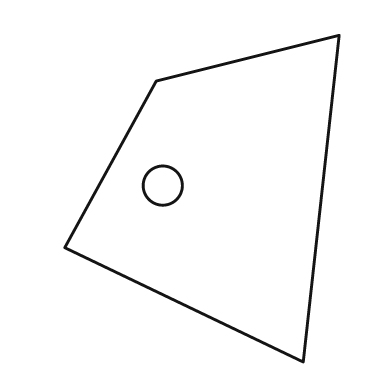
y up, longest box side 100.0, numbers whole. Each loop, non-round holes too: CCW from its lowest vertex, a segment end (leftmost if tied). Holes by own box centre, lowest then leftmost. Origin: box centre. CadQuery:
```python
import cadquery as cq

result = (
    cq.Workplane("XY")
    .moveTo(31.0, -50.0)
    .lineTo(42.0, 50.0)
    .lineTo(-14.0, 36.0)
    .lineTo(-42.0, -15.0)
    .close()
    .moveTo(-12.0, 4.0)
    .circle(6.0)
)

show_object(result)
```